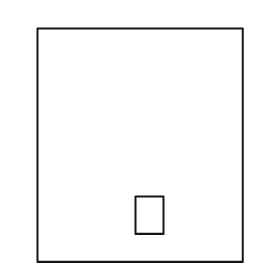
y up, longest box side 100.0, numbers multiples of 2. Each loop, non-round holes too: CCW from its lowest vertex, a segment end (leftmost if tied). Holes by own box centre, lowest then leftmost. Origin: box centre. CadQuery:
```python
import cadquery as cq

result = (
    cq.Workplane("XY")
    .moveTo(-44.0, -50.0)
    .lineTo(44.0, -50.0)
    .lineTo(44.0, 50.0)
    .lineTo(-44.0, 50.0)
    .close()
    .moveTo(-2.0, -38.0)
    .lineTo(10.0, -38.0)
    .lineTo(10.0, -22.0)
    .lineTo(-2.0, -22.0)
    .close()
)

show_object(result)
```